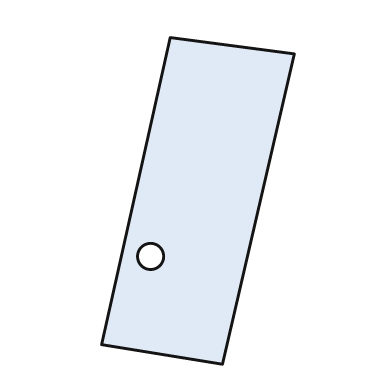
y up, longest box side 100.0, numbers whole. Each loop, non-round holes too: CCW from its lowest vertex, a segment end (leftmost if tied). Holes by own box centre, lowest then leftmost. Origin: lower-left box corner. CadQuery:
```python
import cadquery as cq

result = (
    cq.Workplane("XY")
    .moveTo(37.0, 0.0)
    .lineTo(59.0, 95.0)
    .lineTo(21.0, 100.0)
    .lineTo(0.0, 6.0)
    .close()
    .moveTo(15.0, 33.0)
    .circle(4.0)
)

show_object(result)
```